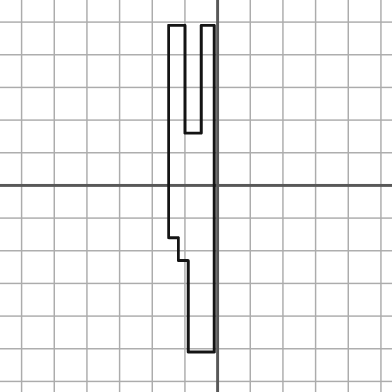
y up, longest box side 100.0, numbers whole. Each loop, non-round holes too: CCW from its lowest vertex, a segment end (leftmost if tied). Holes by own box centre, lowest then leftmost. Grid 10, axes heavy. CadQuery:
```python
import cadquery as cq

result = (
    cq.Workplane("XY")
    .moveTo(-9.0, -51.0)
    .lineTo(-1.0, -51.0)
    .lineTo(-1.0, 49.0)
    .lineTo(-5.0, 49.0)
    .lineTo(-5.0, 16.0)
    .lineTo(-10.0, 16.0)
    .lineTo(-10.0, 49.0)
    .lineTo(-15.0, 49.0)
    .lineTo(-15.0, -16.0)
    .lineTo(-12.0, -16.0)
    .lineTo(-12.0, -23.0)
    .lineTo(-9.0, -23.0)
    .close()
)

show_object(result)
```